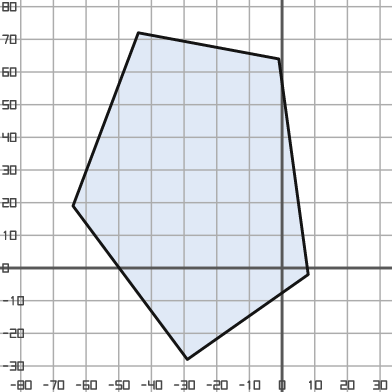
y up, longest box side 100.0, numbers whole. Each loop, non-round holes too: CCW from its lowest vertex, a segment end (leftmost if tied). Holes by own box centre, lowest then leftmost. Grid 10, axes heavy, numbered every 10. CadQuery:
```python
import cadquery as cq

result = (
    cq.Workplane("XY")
    .moveTo(-29.0, -28.0)
    .lineTo(8.0, -2.0)
    .lineTo(-1.0, 64.0)
    .lineTo(-44.0, 72.0)
    .lineTo(-64.0, 19.0)
    .close()
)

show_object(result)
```